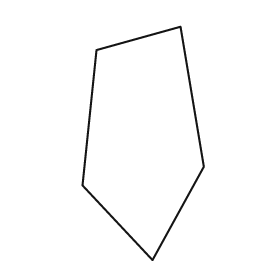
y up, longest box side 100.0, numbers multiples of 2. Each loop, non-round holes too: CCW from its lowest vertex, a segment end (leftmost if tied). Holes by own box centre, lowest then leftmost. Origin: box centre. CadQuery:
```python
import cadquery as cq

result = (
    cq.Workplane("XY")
    .moveTo(4.0, -50.0)
    .lineTo(26.0, -10.0)
    .lineTo(16.0, 50.0)
    .lineTo(-20.0, 40.0)
    .lineTo(-26.0, -18.0)
    .close()
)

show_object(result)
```